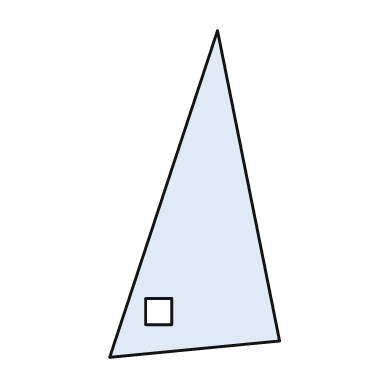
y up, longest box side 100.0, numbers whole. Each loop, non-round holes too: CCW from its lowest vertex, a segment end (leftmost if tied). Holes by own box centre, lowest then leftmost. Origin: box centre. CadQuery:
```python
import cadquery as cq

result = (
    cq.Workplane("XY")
    .moveTo(-26.0, -50.0)
    .lineTo(26.0, -45.0)
    .lineTo(7.0, 50.0)
    .close()
    .moveTo(-15.0, -40.0)
    .lineTo(-7.0, -40.0)
    .lineTo(-7.0, -32.0)
    .lineTo(-15.0, -32.0)
    .close()
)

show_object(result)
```